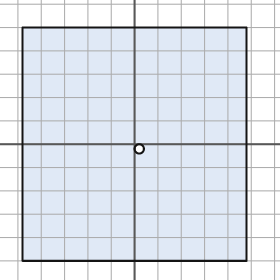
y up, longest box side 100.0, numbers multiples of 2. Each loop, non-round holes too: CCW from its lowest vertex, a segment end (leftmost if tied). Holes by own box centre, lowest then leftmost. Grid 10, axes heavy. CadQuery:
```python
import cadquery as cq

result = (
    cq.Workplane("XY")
    .moveTo(-48.0, -50.0)
    .lineTo(48.0, -50.0)
    .lineTo(48.0, 50.0)
    .lineTo(-48.0, 50.0)
    .close()
    .moveTo(2.0, -2.0)
    .circle(2.0)
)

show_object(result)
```